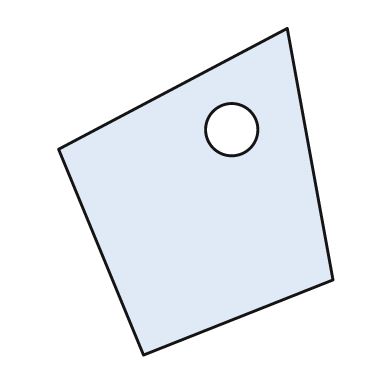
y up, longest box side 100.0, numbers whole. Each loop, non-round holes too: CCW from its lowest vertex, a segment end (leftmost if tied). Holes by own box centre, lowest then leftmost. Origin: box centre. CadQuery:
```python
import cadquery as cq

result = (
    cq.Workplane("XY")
    .moveTo(-16.0, -50.0)
    .lineTo(42.0, -27.0)
    .lineTo(28.0, 50.0)
    .lineTo(-42.0, 13.0)
    .close()
    .moveTo(11.0, 19.0)
    .circle(8.0)
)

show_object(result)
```